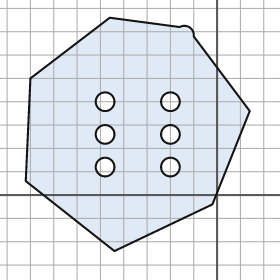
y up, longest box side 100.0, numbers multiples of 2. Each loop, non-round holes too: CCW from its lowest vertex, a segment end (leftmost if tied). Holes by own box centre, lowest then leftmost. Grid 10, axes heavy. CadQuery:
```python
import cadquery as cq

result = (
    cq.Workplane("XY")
    .moveTo(-44.0, -24.0)
    .lineTo(-2.0, -4.0)
    .lineTo(14.0, 36.0)
    .lineTo(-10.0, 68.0)
    .threePointArc((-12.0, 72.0), (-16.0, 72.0))
    .lineTo(-46.0, 76.0)
    .lineTo(-80.0, 50.0)
    .lineTo(-82.0, 6.0)
    .close()
    .moveTo(-48.0, 12.0)
    .circle(4.0)
    .moveTo(-20.0, 12.0)
    .circle(4.0)
    .moveTo(-48.0, 26.0)
    .circle(4.0)
    .moveTo(-20.0, 26.0)
    .circle(4.0)
    .moveTo(-48.0, 40.0)
    .circle(4.0)
    .moveTo(-20.0, 40.0)
    .circle(4.0)
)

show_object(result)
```